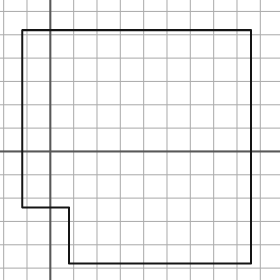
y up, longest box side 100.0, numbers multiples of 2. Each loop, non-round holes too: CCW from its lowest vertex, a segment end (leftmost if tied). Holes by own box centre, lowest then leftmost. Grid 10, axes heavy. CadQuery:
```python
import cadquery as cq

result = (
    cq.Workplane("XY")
    .moveTo(8.0, -48.0)
    .lineTo(86.0, -48.0)
    .lineTo(86.0, 52.0)
    .lineTo(-12.0, 52.0)
    .lineTo(-12.0, -24.0)
    .lineTo(8.0, -24.0)
    .close()
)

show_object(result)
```